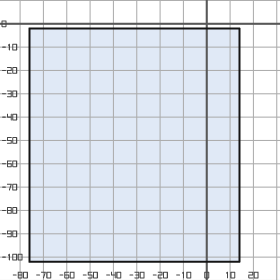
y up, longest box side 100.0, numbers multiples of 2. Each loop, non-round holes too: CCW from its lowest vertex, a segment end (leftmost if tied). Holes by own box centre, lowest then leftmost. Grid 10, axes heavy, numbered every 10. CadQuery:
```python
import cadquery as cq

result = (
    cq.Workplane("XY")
    .moveTo(-76.0, -102.0)
    .lineTo(14.0, -102.0)
    .lineTo(14.0, -2.0)
    .lineTo(-76.0, -2.0)
    .close()
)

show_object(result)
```